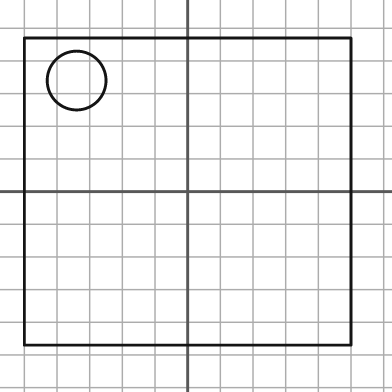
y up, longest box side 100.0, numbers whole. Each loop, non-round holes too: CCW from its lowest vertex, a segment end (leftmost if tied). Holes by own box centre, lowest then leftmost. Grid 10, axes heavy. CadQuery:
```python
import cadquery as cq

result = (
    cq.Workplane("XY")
    .moveTo(-50.0, -47.0)
    .lineTo(50.0, -47.0)
    .lineTo(50.0, 47.0)
    .lineTo(-50.0, 47.0)
    .close()
    .moveTo(-34.0, 34.0)
    .circle(9.0)
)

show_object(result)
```